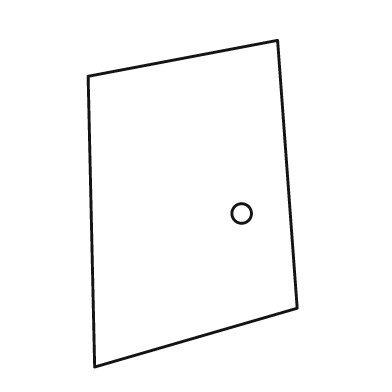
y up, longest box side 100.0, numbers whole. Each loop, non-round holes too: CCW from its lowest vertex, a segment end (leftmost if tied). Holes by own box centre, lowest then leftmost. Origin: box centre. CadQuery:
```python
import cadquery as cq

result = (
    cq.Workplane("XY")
    .moveTo(-30.0, -50.0)
    .lineTo(32.0, -32.0)
    .lineTo(26.0, 50.0)
    .lineTo(-32.0, 39.0)
    .close()
    .moveTo(15.0, -3.0)
    .circle(3.0)
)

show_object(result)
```